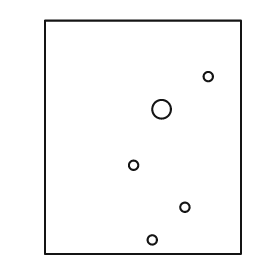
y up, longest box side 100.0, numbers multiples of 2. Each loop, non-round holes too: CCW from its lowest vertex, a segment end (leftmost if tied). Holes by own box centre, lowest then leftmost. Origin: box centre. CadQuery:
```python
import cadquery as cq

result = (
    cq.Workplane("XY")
    .moveTo(-42.0, -50.0)
    .lineTo(42.0, -50.0)
    .lineTo(42.0, 50.0)
    .lineTo(-42.0, 50.0)
    .close()
    .moveTo(4.0, -44.0)
    .circle(2.0)
    .moveTo(18.0, -30.0)
    .circle(2.0)
    .moveTo(-4.0, -12.0)
    .circle(2.0)
    .moveTo(8.0, 12.0)
    .circle(4.0)
    .moveTo(28.0, 26.0)
    .circle(2.0)
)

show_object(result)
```